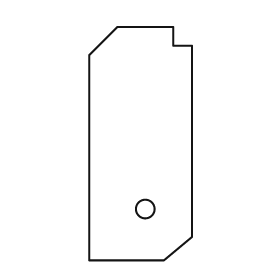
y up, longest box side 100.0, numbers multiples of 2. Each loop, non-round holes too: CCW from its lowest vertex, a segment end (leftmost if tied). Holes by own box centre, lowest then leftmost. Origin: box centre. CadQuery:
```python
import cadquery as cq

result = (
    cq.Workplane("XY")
    .moveTo(-22.0, -50.0)
    .lineTo(10.0, -50.0)
    .lineTo(22.0, -40.0)
    .lineTo(22.0, 42.0)
    .lineTo(14.0, 42.0)
    .lineTo(14.0, 50.0)
    .lineTo(-10.0, 50.0)
    .lineTo(-22.0, 38.0)
    .close()
    .moveTo(2.0, -28.0)
    .circle(4.0)
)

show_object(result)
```